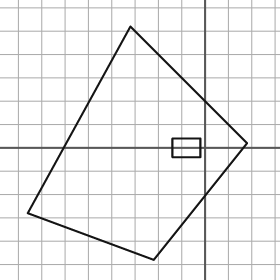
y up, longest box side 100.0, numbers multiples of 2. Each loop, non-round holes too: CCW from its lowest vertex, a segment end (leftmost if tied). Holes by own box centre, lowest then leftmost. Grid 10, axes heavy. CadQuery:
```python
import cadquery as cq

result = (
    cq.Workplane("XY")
    .moveTo(-22.0, -48.0)
    .lineTo(18.0, 2.0)
    .lineTo(-32.0, 52.0)
    .lineTo(-76.0, -28.0)
    .close()
    .moveTo(-14.0, -4.0)
    .lineTo(-2.0, -4.0)
    .lineTo(-2.0, 4.0)
    .lineTo(-14.0, 4.0)
    .close()
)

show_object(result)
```